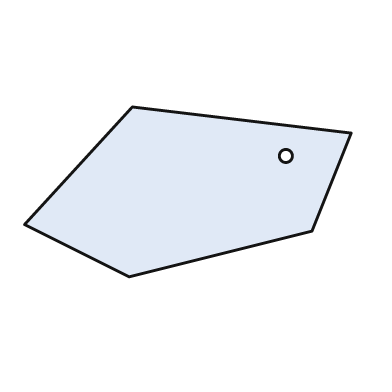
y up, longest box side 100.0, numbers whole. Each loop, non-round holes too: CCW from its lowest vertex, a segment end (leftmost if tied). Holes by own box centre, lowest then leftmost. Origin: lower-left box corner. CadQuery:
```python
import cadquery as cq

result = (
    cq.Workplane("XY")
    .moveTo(32.0, 0.0)
    .lineTo(88.0, 14.0)
    .lineTo(100.0, 44.0)
    .lineTo(33.0, 52.0)
    .lineTo(0.0, 16.0)
    .close()
    .moveTo(80.0, 37.0)
    .circle(2.0)
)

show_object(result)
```